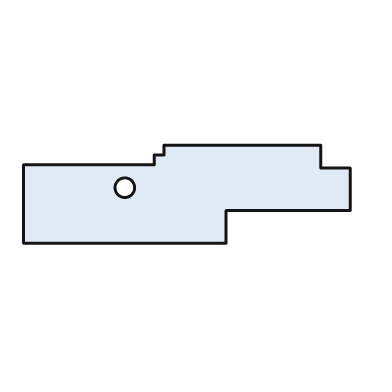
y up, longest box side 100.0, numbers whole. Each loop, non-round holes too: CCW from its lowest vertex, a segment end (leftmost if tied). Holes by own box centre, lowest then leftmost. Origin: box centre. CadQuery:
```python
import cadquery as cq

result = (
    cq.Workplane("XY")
    .moveTo(-50.0, -15.0)
    .lineTo(12.0, -15.0)
    .lineTo(12.0, -5.0)
    .lineTo(50.0, -5.0)
    .lineTo(50.0, 8.0)
    .lineTo(41.0, 8.0)
    .lineTo(41.0, 15.0)
    .lineTo(-7.0, 15.0)
    .lineTo(-7.0, 12.0)
    .lineTo(-10.0, 12.0)
    .lineTo(-10.0, 9.0)
    .lineTo(-50.0, 9.0)
    .close()
    .moveTo(-19.0, 2.0)
    .circle(3.0)
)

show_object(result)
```